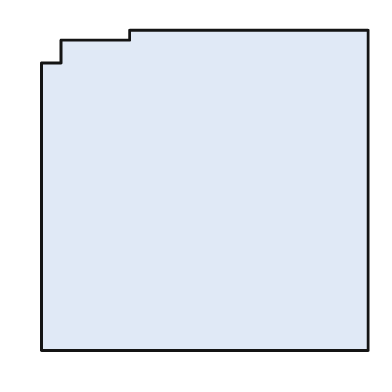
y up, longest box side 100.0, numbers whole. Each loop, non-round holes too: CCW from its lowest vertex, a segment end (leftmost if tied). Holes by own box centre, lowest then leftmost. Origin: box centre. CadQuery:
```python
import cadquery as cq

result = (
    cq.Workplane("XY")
    .moveTo(-50.0, -49.0)
    .lineTo(50.0, -49.0)
    .lineTo(50.0, 49.0)
    .lineTo(-23.0, 49.0)
    .lineTo(-23.0, 46.0)
    .lineTo(-44.0, 46.0)
    .lineTo(-44.0, 39.0)
    .lineTo(-50.0, 39.0)
    .close()
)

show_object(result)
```